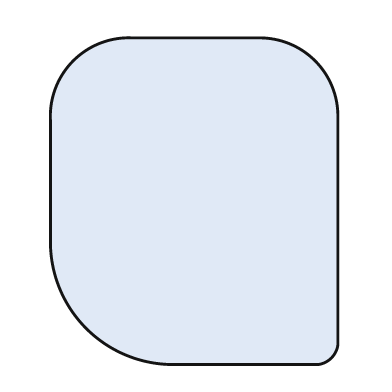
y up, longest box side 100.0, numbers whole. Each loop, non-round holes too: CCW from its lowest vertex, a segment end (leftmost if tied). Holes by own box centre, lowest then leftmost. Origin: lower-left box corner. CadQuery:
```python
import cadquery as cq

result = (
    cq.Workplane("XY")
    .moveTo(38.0, 0.0)
    .lineTo(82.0, 0.0)
    .threePointArc((86.0, 2.0), (88.0, 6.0))
    .lineTo(88.0, 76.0)
    .threePointArc((81.0, 93.0), (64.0, 100.0))
    .lineTo(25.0, 100.0)
    .threePointArc((7.0, 93.0), (0.0, 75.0))
    .lineTo(0.0, 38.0)
    .threePointArc((11.0, 11.0), (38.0, 0.0))
    .close()
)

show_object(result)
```